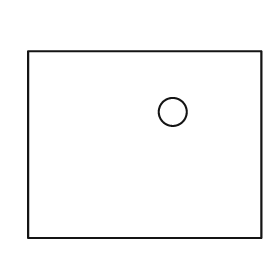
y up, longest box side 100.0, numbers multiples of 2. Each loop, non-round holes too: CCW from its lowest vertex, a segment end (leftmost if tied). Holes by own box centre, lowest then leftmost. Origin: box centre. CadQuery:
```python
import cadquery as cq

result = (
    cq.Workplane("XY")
    .moveTo(-50.0, -40.0)
    .lineTo(50.0, -40.0)
    .lineTo(50.0, 40.0)
    .lineTo(-50.0, 40.0)
    .close()
    .moveTo(12.0, 14.0)
    .circle(6.0)
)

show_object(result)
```